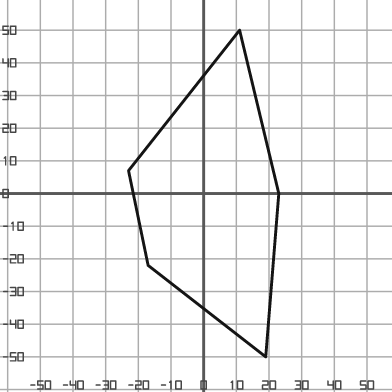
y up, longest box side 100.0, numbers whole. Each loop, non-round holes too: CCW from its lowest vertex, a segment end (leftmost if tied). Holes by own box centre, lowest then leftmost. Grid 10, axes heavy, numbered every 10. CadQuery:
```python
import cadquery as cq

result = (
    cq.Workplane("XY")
    .moveTo(19.0, -50.0)
    .lineTo(23.0, 0.0)
    .lineTo(11.0, 50.0)
    .lineTo(-23.0, 7.0)
    .lineTo(-17.0, -22.0)
    .close()
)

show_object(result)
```